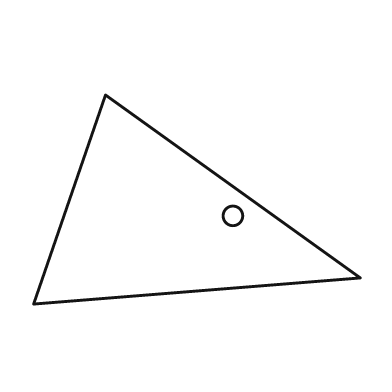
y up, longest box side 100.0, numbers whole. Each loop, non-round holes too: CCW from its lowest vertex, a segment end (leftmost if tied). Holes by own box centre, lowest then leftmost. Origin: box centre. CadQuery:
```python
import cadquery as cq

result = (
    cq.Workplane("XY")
    .moveTo(-50.0, -32.0)
    .lineTo(50.0, -24.0)
    .lineTo(-28.0, 32.0)
    .close()
    .moveTo(11.0, -5.0)
    .circle(3.0)
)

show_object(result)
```